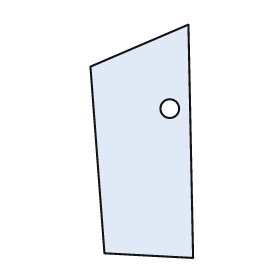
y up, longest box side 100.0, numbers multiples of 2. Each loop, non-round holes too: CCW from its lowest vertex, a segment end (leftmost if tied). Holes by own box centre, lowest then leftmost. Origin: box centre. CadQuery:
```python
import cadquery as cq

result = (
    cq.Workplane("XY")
    .moveTo(22.0, -50.0)
    .lineTo(20.0, 50.0)
    .lineTo(-22.0, 32.0)
    .lineTo(-16.0, -48.0)
    .close()
    .moveTo(12.0, 14.0)
    .circle(4.0)
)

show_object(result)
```